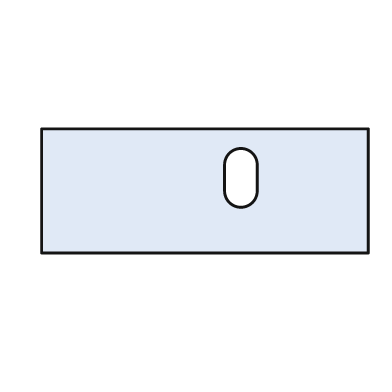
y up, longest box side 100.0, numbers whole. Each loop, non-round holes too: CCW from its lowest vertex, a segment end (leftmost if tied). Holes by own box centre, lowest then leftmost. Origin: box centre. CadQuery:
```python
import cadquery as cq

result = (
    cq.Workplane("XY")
    .moveTo(-50.0, -19.0)
    .lineTo(50.0, -19.0)
    .lineTo(50.0, 19.0)
    .lineTo(-50.0, 19.0)
    .close()
    .moveTo(6.0, 0.0)
    .threePointArc((11.0, -5.0), (16.0, 0.0))
    .lineTo(16.0, 8.0)
    .threePointArc((11.0, 13.0), (6.0, 8.0))
    .close()
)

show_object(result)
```